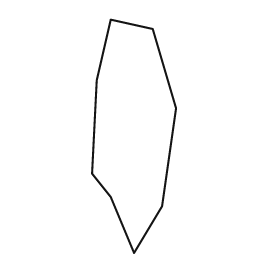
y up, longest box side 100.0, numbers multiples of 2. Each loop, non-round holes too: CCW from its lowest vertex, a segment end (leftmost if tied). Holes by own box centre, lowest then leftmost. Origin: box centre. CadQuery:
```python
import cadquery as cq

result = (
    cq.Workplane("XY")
    .moveTo(0.0, -50.0)
    .lineTo(12.0, -30.0)
    .lineTo(18.0, 12.0)
    .lineTo(8.0, 46.0)
    .lineTo(-10.0, 50.0)
    .lineTo(-16.0, 24.0)
    .lineTo(-18.0, -16.0)
    .lineTo(-10.0, -26.0)
    .close()
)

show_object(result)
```